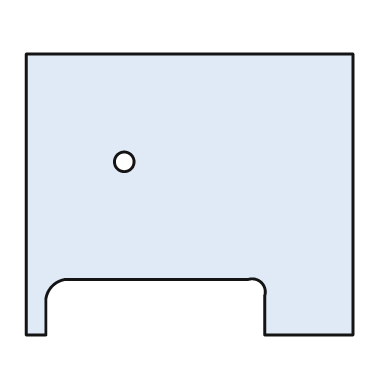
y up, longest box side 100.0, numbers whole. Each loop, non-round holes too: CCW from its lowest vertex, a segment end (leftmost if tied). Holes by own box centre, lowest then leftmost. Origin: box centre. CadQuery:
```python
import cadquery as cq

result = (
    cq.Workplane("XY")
    .moveTo(-50.0, -43.0)
    .lineTo(-44.0, -43.0)
    .lineTo(-44.0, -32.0)
    .threePointArc((-42.0, -28.0), (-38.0, -26.0))
    .lineTo(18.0, -26.0)
    .threePointArc((22.0, -27.0), (23.0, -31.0))
    .lineTo(23.0, -43.0)
    .lineTo(50.0, -43.0)
    .lineTo(50.0, 43.0)
    .lineTo(-50.0, 43.0)
    .close()
    .moveTo(-20.0, 10.0)
    .circle(3.0)
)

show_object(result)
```